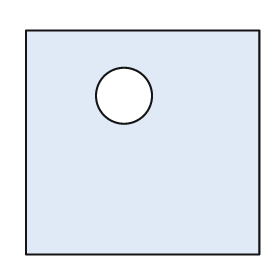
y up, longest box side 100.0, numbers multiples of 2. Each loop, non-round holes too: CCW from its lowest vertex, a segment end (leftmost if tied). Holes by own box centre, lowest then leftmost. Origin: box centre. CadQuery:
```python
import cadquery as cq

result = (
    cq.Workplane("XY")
    .moveTo(-50.0, -48.0)
    .lineTo(50.0, -48.0)
    .lineTo(50.0, 48.0)
    .lineTo(-50.0, 48.0)
    .close()
    .moveTo(-8.0, 20.0)
    .circle(12.0)
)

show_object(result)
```